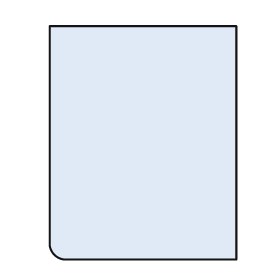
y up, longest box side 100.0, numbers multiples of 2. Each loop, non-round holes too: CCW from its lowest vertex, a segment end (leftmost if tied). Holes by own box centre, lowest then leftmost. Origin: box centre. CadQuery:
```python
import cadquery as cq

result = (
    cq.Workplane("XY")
    .moveTo(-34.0, -50.0)
    .lineTo(40.0, -50.0)
    .lineTo(40.0, 50.0)
    .lineTo(-40.0, 50.0)
    .lineTo(-40.0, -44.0)
    .threePointArc((-38.0, -48.0), (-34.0, -50.0))
    .close()
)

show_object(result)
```